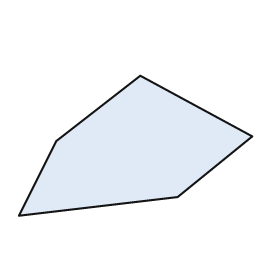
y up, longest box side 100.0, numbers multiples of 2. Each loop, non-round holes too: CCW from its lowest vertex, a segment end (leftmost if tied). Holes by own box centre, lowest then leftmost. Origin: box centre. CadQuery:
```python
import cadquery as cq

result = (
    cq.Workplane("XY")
    .moveTo(-50.0, -30.0)
    .lineTo(18.0, -22.0)
    .lineTo(50.0, 4.0)
    .lineTo(2.0, 30.0)
    .lineTo(-34.0, 2.0)
    .close()
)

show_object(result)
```